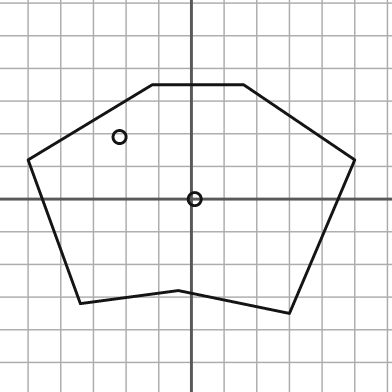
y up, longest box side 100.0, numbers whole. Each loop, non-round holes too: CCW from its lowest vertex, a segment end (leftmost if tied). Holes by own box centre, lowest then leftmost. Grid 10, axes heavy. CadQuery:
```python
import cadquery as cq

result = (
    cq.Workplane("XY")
    .moveTo(30.0, -35.0)
    .lineTo(50.0, 12.0)
    .lineTo(16.0, 35.0)
    .lineTo(-12.0, 35.0)
    .lineTo(-50.0, 12.0)
    .lineTo(-34.0, -32.0)
    .lineTo(-4.0, -28.0)
    .close()
    .moveTo(1.0, 0.0)
    .circle(2.0)
    .moveTo(-22.0, 19.0)
    .circle(2.0)
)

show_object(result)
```